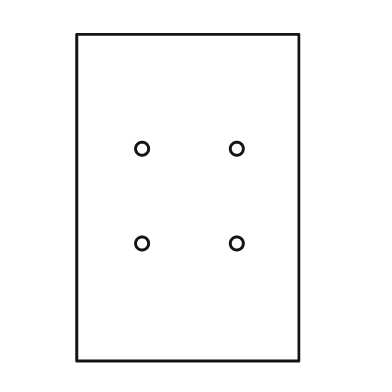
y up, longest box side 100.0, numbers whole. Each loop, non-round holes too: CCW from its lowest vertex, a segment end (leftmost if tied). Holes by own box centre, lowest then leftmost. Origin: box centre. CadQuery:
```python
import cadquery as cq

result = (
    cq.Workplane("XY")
    .moveTo(-34.0, -50.0)
    .lineTo(34.0, -50.0)
    .lineTo(34.0, 50.0)
    .lineTo(-34.0, 50.0)
    .close()
    .moveTo(-14.0, -14.0)
    .circle(2.0)
    .moveTo(15.0, -14.0)
    .circle(2.0)
    .moveTo(-14.0, 15.0)
    .circle(2.0)
    .moveTo(15.0, 15.0)
    .circle(2.0)
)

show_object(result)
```